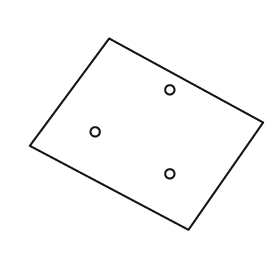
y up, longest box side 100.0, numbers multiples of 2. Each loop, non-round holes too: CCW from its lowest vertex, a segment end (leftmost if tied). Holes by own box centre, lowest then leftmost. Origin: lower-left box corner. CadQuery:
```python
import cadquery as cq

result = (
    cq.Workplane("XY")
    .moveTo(68.0, 0.0)
    .lineTo(100.0, 46.0)
    .lineTo(34.0, 82.0)
    .lineTo(0.0, 36.0)
    .close()
    .moveTo(60.0, 24.0)
    .circle(2.0)
    .moveTo(28.0, 42.0)
    .circle(2.0)
    .moveTo(60.0, 60.0)
    .circle(2.0)
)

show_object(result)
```